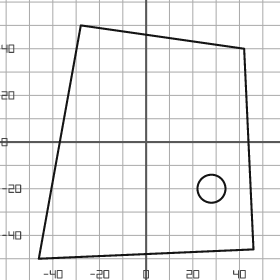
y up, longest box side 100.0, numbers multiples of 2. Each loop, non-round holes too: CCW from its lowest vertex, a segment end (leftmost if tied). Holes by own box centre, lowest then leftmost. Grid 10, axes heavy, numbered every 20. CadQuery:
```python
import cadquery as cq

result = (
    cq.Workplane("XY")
    .moveTo(-46.0, -50.0)
    .lineTo(46.0, -46.0)
    .lineTo(42.0, 40.0)
    .lineTo(-28.0, 50.0)
    .close()
    .moveTo(28.0, -20.0)
    .circle(6.0)
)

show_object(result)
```